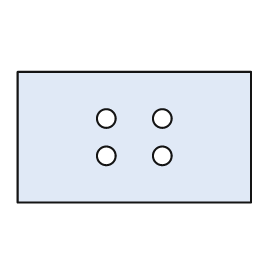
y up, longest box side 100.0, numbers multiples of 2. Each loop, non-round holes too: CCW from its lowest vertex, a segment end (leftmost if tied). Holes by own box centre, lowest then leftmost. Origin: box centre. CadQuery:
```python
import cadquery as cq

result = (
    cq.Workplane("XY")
    .moveTo(-50.0, -28.0)
    .lineTo(50.0, -28.0)
    .lineTo(50.0, 28.0)
    .lineTo(-50.0, 28.0)
    .close()
    .moveTo(-12.0, -8.0)
    .circle(4.0)
    .moveTo(12.0, -8.0)
    .circle(4.0)
    .moveTo(-12.0, 8.0)
    .circle(4.0)
    .moveTo(12.0, 8.0)
    .circle(4.0)
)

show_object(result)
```